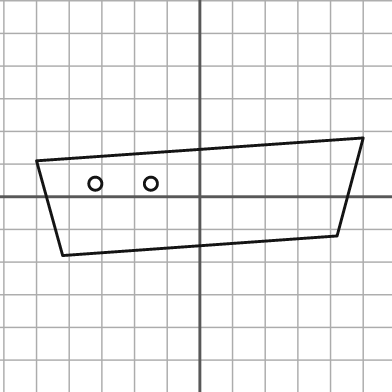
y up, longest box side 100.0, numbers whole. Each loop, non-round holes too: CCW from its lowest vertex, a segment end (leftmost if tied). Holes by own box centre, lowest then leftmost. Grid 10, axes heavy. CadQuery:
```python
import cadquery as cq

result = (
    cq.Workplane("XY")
    .moveTo(-42.0, -18.0)
    .lineTo(42.0, -12.0)
    .lineTo(50.0, 18.0)
    .lineTo(-50.0, 11.0)
    .close()
    .moveTo(-32.0, 4.0)
    .circle(2.0)
    .moveTo(-15.0, 4.0)
    .circle(2.0)
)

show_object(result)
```